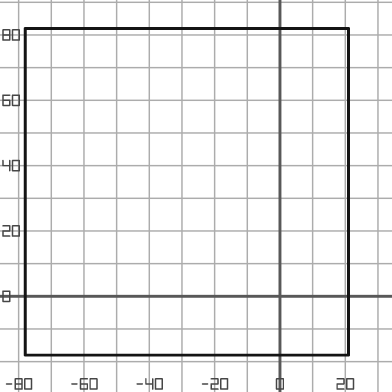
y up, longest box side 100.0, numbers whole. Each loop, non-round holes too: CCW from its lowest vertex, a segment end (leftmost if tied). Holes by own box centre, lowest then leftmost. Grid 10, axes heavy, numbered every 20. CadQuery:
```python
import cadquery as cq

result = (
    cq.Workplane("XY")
    .moveTo(-78.0, -18.0)
    .lineTo(21.0, -18.0)
    .lineTo(21.0, 82.0)
    .lineTo(-78.0, 82.0)
    .close()
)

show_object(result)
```